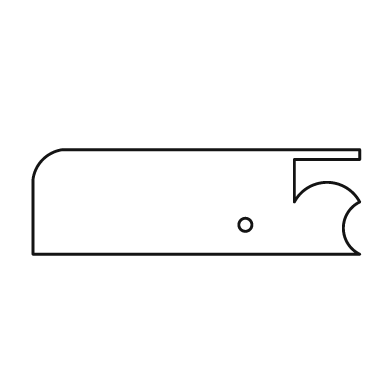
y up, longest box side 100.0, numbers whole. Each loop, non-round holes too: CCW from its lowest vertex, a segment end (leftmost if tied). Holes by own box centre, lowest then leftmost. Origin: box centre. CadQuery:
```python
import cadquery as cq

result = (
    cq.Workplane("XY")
    .moveTo(-50.0, -16.0)
    .lineTo(50.0, -16.0)
    .threePointArc((45.0, -8.0), (50.0, 0.0))
    .threePointArc((40.0, 6.0), (30.0, 0.0))
    .lineTo(30.0, 13.0)
    .lineTo(50.0, 13.0)
    .lineTo(50.0, 16.0)
    .lineTo(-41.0, 16.0)
    .threePointArc((-47.0, 13.0), (-50.0, 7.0))
    .close()
    .moveTo(15.0, -7.0)
    .circle(2.0)
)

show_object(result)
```